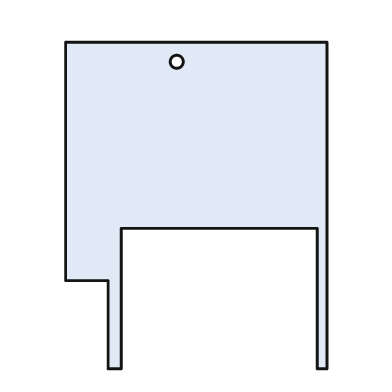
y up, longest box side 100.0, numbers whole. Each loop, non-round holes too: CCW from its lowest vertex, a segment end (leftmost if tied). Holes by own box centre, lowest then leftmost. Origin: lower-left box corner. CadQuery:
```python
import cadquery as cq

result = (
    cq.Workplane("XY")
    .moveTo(13.0, 0.0)
    .lineTo(17.0, 0.0)
    .lineTo(17.0, 43.0)
    .lineTo(77.0, 43.0)
    .lineTo(77.0, 0.0)
    .lineTo(80.0, 0.0)
    .lineTo(80.0, 100.0)
    .lineTo(0.0, 100.0)
    .lineTo(0.0, 27.0)
    .lineTo(13.0, 27.0)
    .close()
    .moveTo(34.0, 94.0)
    .circle(2.0)
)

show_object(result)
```